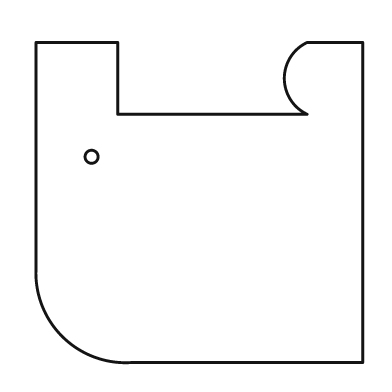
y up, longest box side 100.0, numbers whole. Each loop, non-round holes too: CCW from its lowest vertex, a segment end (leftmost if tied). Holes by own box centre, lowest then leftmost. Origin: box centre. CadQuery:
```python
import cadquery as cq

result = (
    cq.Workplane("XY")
    .moveTo(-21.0, -49.0)
    .lineTo(50.0, -49.0)
    .lineTo(50.0, 49.0)
    .lineTo(33.0, 49.0)
    .threePointArc((26.0, 38.0), (33.0, 27.0))
    .lineTo(-25.0, 27.0)
    .lineTo(-25.0, 49.0)
    .lineTo(-50.0, 49.0)
    .lineTo(-50.0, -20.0)
    .threePointArc((-42.0, -41.0), (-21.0, -49.0))
    .close()
    .moveTo(-33.0, 14.0)
    .circle(2.0)
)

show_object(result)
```